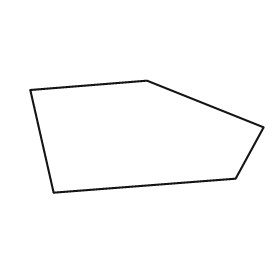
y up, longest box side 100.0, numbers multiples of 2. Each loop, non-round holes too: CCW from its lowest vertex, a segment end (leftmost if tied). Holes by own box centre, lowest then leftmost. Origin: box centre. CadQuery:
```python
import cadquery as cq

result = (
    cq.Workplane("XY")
    .moveTo(-40.0, -24.0)
    .lineTo(38.0, -18.0)
    .lineTo(50.0, 4.0)
    .lineTo(0.0, 24.0)
    .lineTo(-50.0, 20.0)
    .close()
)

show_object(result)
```